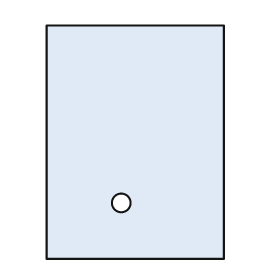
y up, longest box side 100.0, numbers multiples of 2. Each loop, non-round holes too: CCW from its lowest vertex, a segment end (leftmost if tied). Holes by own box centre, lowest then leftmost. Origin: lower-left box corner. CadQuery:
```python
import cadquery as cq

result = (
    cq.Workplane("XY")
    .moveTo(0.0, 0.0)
    .lineTo(76.0, 0.0)
    .lineTo(76.0, 100.0)
    .lineTo(0.0, 100.0)
    .close()
    .moveTo(32.0, 24.0)
    .circle(4.0)
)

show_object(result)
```